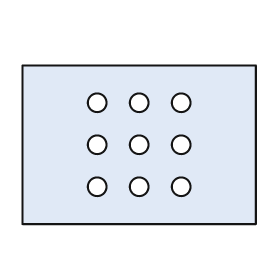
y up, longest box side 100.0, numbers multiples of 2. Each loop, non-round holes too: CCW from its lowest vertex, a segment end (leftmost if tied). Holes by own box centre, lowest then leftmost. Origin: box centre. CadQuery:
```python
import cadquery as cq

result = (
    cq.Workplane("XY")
    .moveTo(-50.0, -34.0)
    .lineTo(50.0, -34.0)
    .lineTo(50.0, 34.0)
    .lineTo(-50.0, 34.0)
    .close()
    .moveTo(-18.0, -18.0)
    .circle(4.0)
    .moveTo(0.0, -18.0)
    .circle(4.0)
    .moveTo(18.0, -18.0)
    .circle(4.0)
    .moveTo(-18.0, 0.0)
    .circle(4.0)
    .moveTo(0.0, 0.0)
    .circle(4.0)
    .moveTo(18.0, 0.0)
    .circle(4.0)
    .moveTo(-18.0, 18.0)
    .circle(4.0)
    .moveTo(0.0, 18.0)
    .circle(4.0)
    .moveTo(18.0, 18.0)
    .circle(4.0)
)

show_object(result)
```